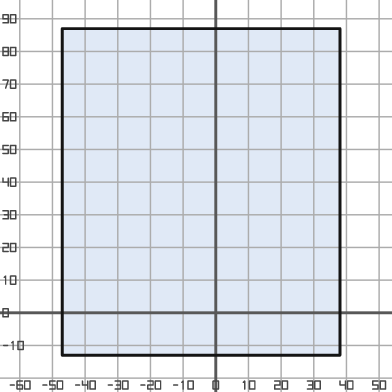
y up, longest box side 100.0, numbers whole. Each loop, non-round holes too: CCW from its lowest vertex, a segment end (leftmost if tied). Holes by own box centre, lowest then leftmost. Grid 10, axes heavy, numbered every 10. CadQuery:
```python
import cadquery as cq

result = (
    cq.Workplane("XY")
    .moveTo(-47.0, -13.0)
    .lineTo(38.0, -13.0)
    .lineTo(38.0, 87.0)
    .lineTo(-47.0, 87.0)
    .close()
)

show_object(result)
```